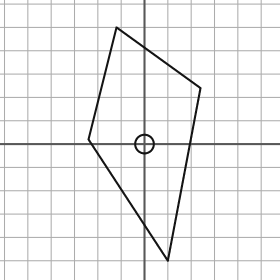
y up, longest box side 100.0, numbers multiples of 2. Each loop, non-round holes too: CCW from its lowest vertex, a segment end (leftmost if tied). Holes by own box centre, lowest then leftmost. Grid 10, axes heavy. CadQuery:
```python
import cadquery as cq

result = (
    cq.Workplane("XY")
    .moveTo(10.0, -50.0)
    .lineTo(24.0, 24.0)
    .lineTo(-12.0, 50.0)
    .lineTo(-24.0, 2.0)
    .close()
    .moveTo(0.0, 0.0)
    .circle(4.0)
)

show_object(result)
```